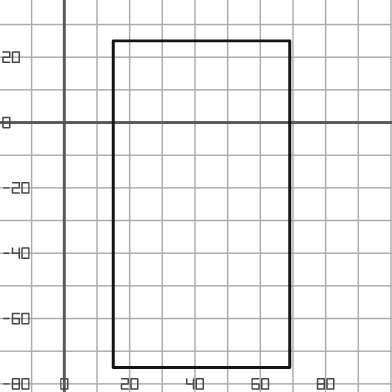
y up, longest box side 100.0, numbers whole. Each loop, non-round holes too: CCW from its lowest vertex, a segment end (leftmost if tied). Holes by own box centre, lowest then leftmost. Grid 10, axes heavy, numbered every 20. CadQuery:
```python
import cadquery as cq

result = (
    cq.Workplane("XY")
    .moveTo(15.0, -75.0)
    .lineTo(69.0, -75.0)
    .lineTo(69.0, 25.0)
    .lineTo(15.0, 25.0)
    .close()
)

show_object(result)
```